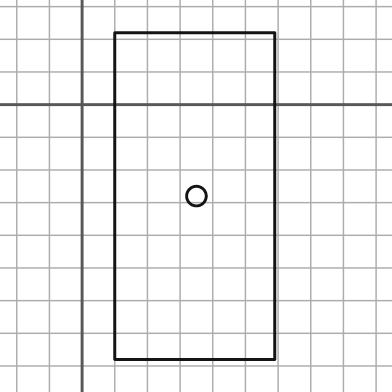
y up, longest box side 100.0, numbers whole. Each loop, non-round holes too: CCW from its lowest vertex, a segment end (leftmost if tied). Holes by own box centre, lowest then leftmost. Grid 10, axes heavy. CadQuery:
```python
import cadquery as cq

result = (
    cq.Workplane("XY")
    .moveTo(10.0, -78.0)
    .lineTo(59.0, -78.0)
    .lineTo(59.0, 22.0)
    .lineTo(10.0, 22.0)
    .close()
    .moveTo(35.0, -28.0)
    .circle(3.0)
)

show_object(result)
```